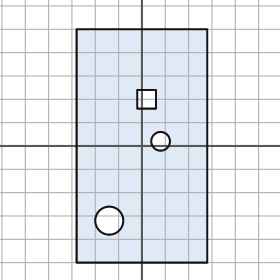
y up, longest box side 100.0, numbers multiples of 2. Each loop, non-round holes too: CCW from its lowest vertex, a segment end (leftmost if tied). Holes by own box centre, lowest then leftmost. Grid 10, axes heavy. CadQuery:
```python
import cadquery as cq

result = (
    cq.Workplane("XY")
    .moveTo(-28.0, -50.0)
    .lineTo(28.0, -50.0)
    .lineTo(28.0, 50.0)
    .lineTo(-28.0, 50.0)
    .close()
    .moveTo(-14.0, -32.0)
    .circle(6.0)
    .moveTo(8.0, 2.0)
    .circle(4.0)
    .moveTo(-2.0, 16.0)
    .lineTo(6.0, 16.0)
    .lineTo(6.0, 24.0)
    .lineTo(-2.0, 24.0)
    .close()
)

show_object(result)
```